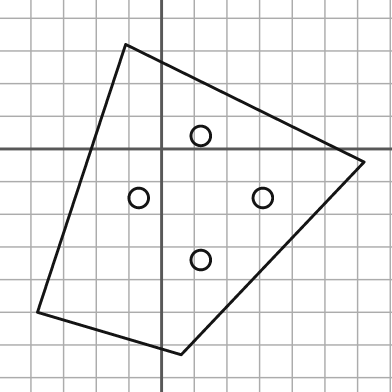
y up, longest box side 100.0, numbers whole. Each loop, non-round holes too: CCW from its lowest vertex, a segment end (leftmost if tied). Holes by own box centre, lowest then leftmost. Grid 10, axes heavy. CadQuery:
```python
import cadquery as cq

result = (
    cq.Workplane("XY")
    .moveTo(6.0, -63.0)
    .lineTo(62.0, -4.0)
    .lineTo(-11.0, 32.0)
    .lineTo(-38.0, -50.0)
    .close()
    .moveTo(12.0, -34.0)
    .circle(3.0)
    .moveTo(-7.0, -15.0)
    .circle(3.0)
    .moveTo(31.0, -15.0)
    .circle(3.0)
    .moveTo(12.0, 4.0)
    .circle(3.0)
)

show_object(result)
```